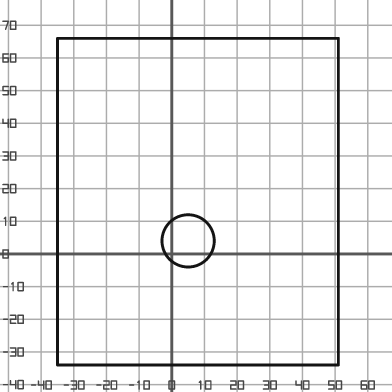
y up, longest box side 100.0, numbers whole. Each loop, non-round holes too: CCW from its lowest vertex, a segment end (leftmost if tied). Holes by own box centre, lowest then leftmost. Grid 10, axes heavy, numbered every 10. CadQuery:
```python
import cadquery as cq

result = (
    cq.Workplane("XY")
    .moveTo(-35.0, -34.0)
    .lineTo(51.0, -34.0)
    .lineTo(51.0, 66.0)
    .lineTo(-35.0, 66.0)
    .close()
    .moveTo(5.0, 4.0)
    .circle(8.0)
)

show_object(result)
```